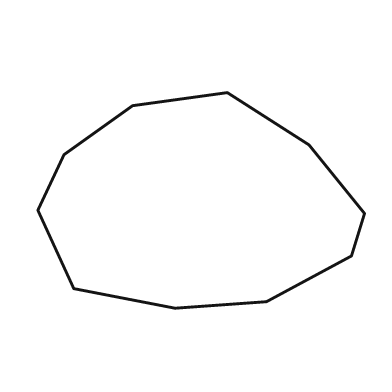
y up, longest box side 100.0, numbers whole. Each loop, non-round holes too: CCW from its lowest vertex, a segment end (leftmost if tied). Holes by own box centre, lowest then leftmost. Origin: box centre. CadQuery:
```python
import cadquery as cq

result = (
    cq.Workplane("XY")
    .moveTo(-8.0, -33.0)
    .lineTo(20.0, -31.0)
    .lineTo(46.0, -17.0)
    .lineTo(50.0, -4.0)
    .lineTo(33.0, 17.0)
    .lineTo(8.0, 33.0)
    .lineTo(-21.0, 29.0)
    .lineTo(-42.0, 14.0)
    .lineTo(-50.0, -3.0)
    .lineTo(-39.0, -27.0)
    .close()
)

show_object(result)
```